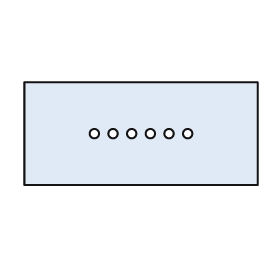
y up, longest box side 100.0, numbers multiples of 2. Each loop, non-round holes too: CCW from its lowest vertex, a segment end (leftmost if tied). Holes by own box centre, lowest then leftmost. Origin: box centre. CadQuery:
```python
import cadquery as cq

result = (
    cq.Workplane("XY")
    .moveTo(-50.0, -22.0)
    .lineTo(50.0, -22.0)
    .lineTo(50.0, 22.0)
    .lineTo(-50.0, 22.0)
    .close()
    .moveTo(-20.0, 0.0)
    .circle(2.0)
    .moveTo(-12.0, 0.0)
    .circle(2.0)
    .moveTo(-4.0, 0.0)
    .circle(2.0)
    .moveTo(4.0, 0.0)
    .circle(2.0)
    .moveTo(12.0, 0.0)
    .circle(2.0)
    .moveTo(20.0, 0.0)
    .circle(2.0)
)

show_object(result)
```